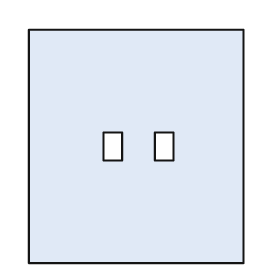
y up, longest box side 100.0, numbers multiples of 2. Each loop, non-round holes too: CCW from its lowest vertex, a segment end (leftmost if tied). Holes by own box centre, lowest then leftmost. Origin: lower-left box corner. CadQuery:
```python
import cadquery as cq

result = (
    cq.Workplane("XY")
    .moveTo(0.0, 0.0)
    .lineTo(92.0, 0.0)
    .lineTo(92.0, 100.0)
    .lineTo(0.0, 100.0)
    .close()
    .moveTo(32.0, 44.0)
    .lineTo(40.0, 44.0)
    .lineTo(40.0, 56.0)
    .lineTo(32.0, 56.0)
    .close()
    .moveTo(54.0, 44.0)
    .lineTo(62.0, 44.0)
    .lineTo(62.0, 56.0)
    .lineTo(54.0, 56.0)
    .close()
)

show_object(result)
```